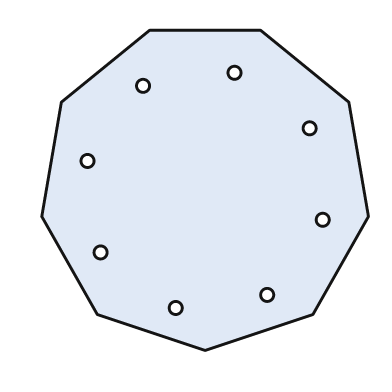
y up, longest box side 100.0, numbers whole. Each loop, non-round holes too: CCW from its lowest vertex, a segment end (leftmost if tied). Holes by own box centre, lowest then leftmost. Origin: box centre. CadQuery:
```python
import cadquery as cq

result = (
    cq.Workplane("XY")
    .moveTo(0.0, -49.0)
    .lineTo(33.0, -38.0)
    .lineTo(50.0, -8.0)
    .lineTo(44.0, 27.0)
    .lineTo(17.0, 49.0)
    .lineTo(-17.0, 49.0)
    .lineTo(-44.0, 27.0)
    .lineTo(-50.0, -8.0)
    .lineTo(-33.0, -38.0)
    .close()
    .moveTo(-9.0, -36.0)
    .circle(2.0)
    .moveTo(19.0, -32.0)
    .circle(2.0)
    .moveTo(-32.0, -19.0)
    .circle(2.0)
    .moveTo(36.0, -9.0)
    .circle(2.0)
    .moveTo(-36.0, 9.0)
    .circle(2.0)
    .moveTo(32.0, 19.0)
    .circle(2.0)
    .moveTo(-19.0, 32.0)
    .circle(2.0)
    .moveTo(9.0, 36.0)
    .circle(2.0)
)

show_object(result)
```